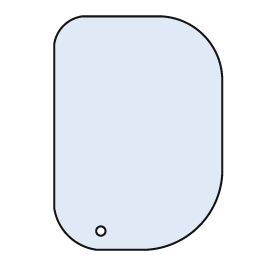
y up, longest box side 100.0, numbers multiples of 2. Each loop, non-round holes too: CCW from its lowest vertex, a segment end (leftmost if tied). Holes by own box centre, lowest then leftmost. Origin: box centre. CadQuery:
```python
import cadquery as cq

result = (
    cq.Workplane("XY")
    .moveTo(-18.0, -50.0)
    .lineTo(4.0, -50.0)
    .threePointArc((26.0, -40.0), (36.0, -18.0))
    .lineTo(36.0, 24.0)
    .threePointArc((28.0, 42.0), (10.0, 50.0))
    .lineTo(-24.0, 50.0)
    .threePointArc((-32.0, 46.0), (-36.0, 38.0))
    .lineTo(-36.0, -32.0)
    .threePointArc((-30.0, -44.0), (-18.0, -50.0))
    .close()
    .moveTo(-16.0, -42.0)
    .circle(2.0)
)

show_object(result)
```